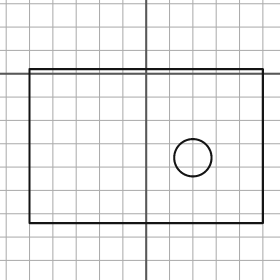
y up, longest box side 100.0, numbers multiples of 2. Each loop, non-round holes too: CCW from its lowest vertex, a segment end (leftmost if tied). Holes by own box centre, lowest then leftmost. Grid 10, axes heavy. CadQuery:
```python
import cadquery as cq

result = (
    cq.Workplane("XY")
    .moveTo(-50.0, -64.0)
    .lineTo(50.0, -64.0)
    .lineTo(50.0, 2.0)
    .lineTo(-50.0, 2.0)
    .close()
    .moveTo(20.0, -36.0)
    .circle(8.0)
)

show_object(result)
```